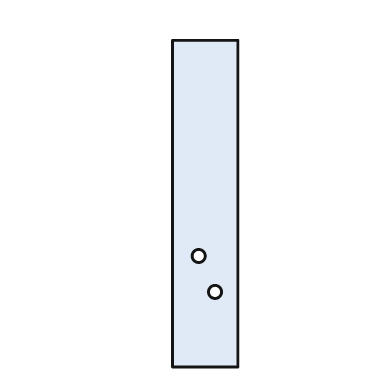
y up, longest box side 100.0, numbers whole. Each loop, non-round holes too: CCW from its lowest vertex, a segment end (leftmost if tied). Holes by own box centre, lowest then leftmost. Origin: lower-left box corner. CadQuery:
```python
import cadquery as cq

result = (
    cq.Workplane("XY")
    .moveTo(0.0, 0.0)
    .lineTo(20.0, 0.0)
    .lineTo(20.0, 100.0)
    .lineTo(0.0, 100.0)
    .close()
    .moveTo(13.0, 23.0)
    .circle(2.0)
    .moveTo(8.0, 34.0)
    .circle(2.0)
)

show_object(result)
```